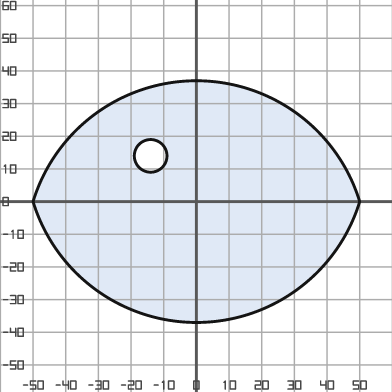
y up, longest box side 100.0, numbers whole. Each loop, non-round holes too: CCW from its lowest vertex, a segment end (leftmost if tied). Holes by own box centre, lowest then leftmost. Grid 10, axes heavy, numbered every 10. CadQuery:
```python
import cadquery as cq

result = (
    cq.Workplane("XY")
    .moveTo(-50.0, 0.0)
    .threePointArc((0.0, -37.0), (50.0, 0.0))
    .threePointArc((0.0, 37.0), (-50.0, 0.0))
    .close()
    .moveTo(-14.0, 14.0)
    .circle(5.0)
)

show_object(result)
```